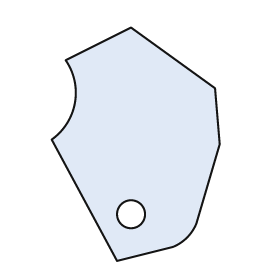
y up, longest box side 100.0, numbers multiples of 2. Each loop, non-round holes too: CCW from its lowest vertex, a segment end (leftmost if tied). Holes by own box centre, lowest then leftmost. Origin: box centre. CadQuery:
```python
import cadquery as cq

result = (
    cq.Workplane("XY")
    .moveTo(-8.0, -50.0)
    .lineTo(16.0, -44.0)
    .threePointArc((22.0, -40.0), (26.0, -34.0))
    .lineTo(36.0, 0.0)
    .lineTo(34.0, 24.0)
    .lineTo(-2.0, 50.0)
    .lineTo(-30.0, 36.0)
    .threePointArc((-26.0, 18.0), (-36.0, 2.0))
    .close()
    .moveTo(-2.0, -30.0)
    .circle(6.0)
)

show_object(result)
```